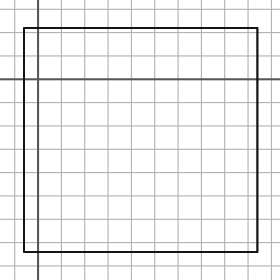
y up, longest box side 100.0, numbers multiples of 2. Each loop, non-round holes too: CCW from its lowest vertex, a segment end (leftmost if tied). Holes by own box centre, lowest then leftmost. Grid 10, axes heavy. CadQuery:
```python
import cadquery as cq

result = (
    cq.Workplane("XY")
    .moveTo(-6.0, -74.0)
    .lineTo(94.0, -74.0)
    .lineTo(94.0, 22.0)
    .lineTo(-6.0, 22.0)
    .close()
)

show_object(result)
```